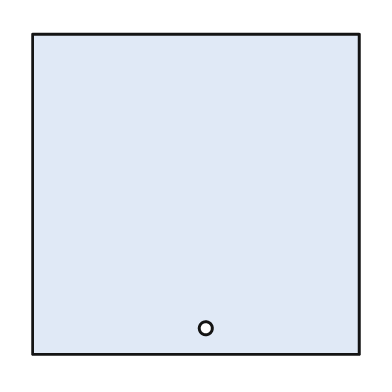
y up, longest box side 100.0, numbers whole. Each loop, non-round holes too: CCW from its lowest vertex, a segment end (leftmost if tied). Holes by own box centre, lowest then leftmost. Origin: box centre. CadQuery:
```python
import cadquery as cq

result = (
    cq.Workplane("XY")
    .moveTo(-50.0, -49.0)
    .lineTo(50.0, -49.0)
    .lineTo(50.0, 49.0)
    .lineTo(-50.0, 49.0)
    .close()
    .moveTo(3.0, -41.0)
    .circle(2.0)
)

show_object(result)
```